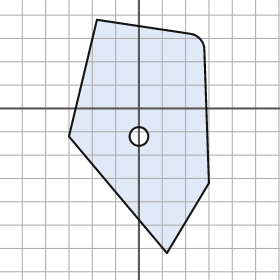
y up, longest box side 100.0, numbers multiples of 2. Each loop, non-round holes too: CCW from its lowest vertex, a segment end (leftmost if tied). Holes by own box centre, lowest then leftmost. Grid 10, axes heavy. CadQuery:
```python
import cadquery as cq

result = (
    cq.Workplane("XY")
    .moveTo(12.0, -62.0)
    .lineTo(30.0, -32.0)
    .lineTo(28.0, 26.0)
    .threePointArc((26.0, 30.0), (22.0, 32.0))
    .lineTo(-18.0, 38.0)
    .lineTo(-30.0, -12.0)
    .close()
    .moveTo(0.0, -12.0)
    .circle(4.0)
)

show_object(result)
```